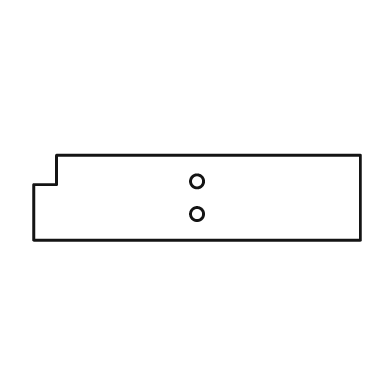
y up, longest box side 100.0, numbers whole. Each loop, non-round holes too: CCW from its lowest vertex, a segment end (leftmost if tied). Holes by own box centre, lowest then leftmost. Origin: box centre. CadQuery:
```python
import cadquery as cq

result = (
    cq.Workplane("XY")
    .moveTo(-50.0, -13.0)
    .lineTo(50.0, -13.0)
    .lineTo(50.0, 13.0)
    .lineTo(-43.0, 13.0)
    .lineTo(-43.0, 4.0)
    .lineTo(-50.0, 4.0)
    .close()
    .moveTo(0.0, -5.0)
    .circle(2.0)
    .moveTo(0.0, 5.0)
    .circle(2.0)
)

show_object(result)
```